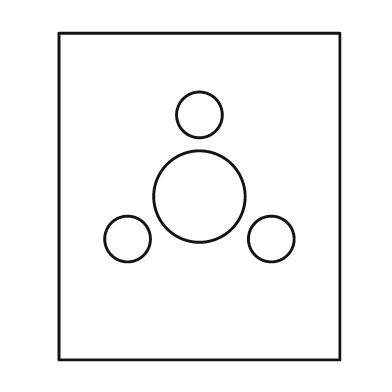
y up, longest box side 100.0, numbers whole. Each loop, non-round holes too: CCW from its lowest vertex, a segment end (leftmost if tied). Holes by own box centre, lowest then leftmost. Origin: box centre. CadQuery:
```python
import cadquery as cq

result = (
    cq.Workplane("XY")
    .moveTo(-43.0, -50.0)
    .lineTo(43.0, -50.0)
    .lineTo(43.0, 50.0)
    .lineTo(-43.0, 50.0)
    .close()
    .moveTo(-22.0, -13.0)
    .circle(7.0)
    .moveTo(22.0, -13.0)
    .circle(7.0)
    .moveTo(0.0, 0.0)
    .circle(14.0)
    .moveTo(0.0, 25.0)
    .circle(7.0)
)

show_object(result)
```